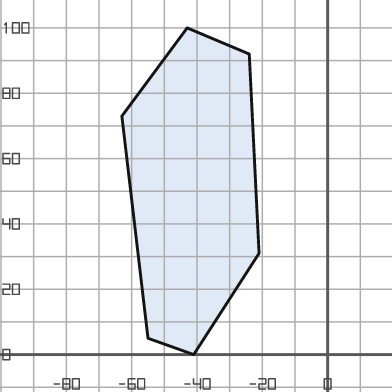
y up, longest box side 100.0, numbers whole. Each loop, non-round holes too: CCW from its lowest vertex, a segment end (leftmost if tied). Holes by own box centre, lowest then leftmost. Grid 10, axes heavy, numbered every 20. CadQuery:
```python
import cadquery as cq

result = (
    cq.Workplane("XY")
    .moveTo(-41.0, 0.0)
    .lineTo(-21.0, 31.0)
    .lineTo(-24.0, 92.0)
    .lineTo(-43.0, 100.0)
    .lineTo(-63.0, 73.0)
    .lineTo(-55.0, 5.0)
    .close()
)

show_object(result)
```